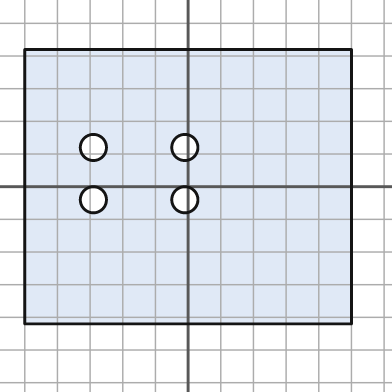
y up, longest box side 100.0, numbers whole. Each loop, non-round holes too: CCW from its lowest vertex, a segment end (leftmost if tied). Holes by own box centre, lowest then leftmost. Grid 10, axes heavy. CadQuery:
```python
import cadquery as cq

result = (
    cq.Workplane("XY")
    .moveTo(-50.0, -42.0)
    .lineTo(50.0, -42.0)
    .lineTo(50.0, 42.0)
    .lineTo(-50.0, 42.0)
    .close()
    .moveTo(-29.0, -4.0)
    .circle(4.0)
    .moveTo(-1.0, -4.0)
    .circle(4.0)
    .moveTo(-29.0, 12.0)
    .circle(4.0)
    .moveTo(-1.0, 12.0)
    .circle(4.0)
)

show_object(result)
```